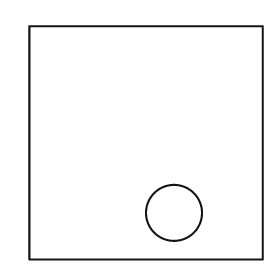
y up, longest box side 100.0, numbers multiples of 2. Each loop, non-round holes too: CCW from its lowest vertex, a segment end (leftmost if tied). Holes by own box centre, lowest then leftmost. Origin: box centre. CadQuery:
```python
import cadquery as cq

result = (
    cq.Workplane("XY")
    .moveTo(-50.0, -50.0)
    .lineTo(50.0, -50.0)
    .lineTo(50.0, 50.0)
    .lineTo(-50.0, 50.0)
    .close()
    .moveTo(12.0, -30.0)
    .circle(12.0)
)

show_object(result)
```